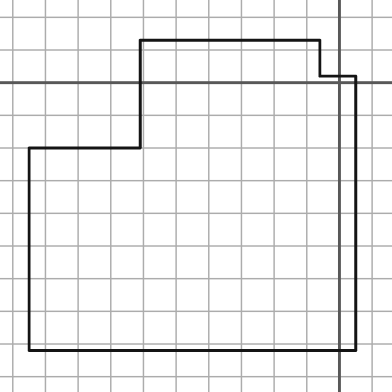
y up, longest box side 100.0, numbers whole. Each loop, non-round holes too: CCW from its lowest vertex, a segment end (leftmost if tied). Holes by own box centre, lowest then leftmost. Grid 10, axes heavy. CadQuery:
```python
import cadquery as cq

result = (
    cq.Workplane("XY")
    .moveTo(-95.0, -82.0)
    .lineTo(5.0, -82.0)
    .lineTo(5.0, 2.0)
    .lineTo(-6.0, 2.0)
    .lineTo(-6.0, 13.0)
    .lineTo(-61.0, 13.0)
    .lineTo(-61.0, -20.0)
    .lineTo(-95.0, -20.0)
    .close()
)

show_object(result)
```